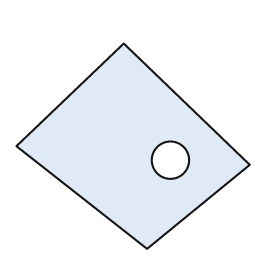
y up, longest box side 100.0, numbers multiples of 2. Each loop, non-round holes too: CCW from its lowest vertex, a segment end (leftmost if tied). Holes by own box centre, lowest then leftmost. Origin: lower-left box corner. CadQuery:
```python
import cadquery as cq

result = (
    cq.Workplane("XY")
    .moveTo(56.0, 0.0)
    .lineTo(100.0, 36.0)
    .lineTo(46.0, 88.0)
    .lineTo(0.0, 44.0)
    .close()
    .moveTo(66.0, 38.0)
    .circle(8.0)
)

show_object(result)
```